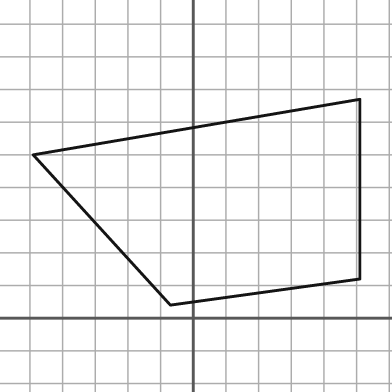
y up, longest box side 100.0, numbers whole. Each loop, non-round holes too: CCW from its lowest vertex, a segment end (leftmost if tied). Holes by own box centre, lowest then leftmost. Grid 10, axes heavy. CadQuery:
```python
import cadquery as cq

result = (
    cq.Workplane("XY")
    .moveTo(-7.0, 4.0)
    .lineTo(51.0, 12.0)
    .lineTo(51.0, 67.0)
    .lineTo(-49.0, 50.0)
    .close()
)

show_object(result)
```